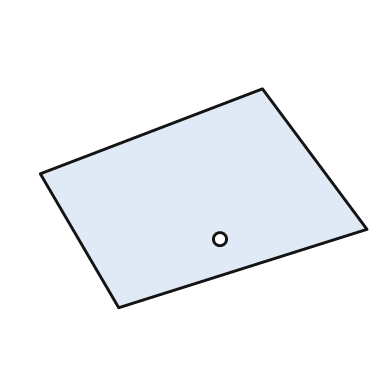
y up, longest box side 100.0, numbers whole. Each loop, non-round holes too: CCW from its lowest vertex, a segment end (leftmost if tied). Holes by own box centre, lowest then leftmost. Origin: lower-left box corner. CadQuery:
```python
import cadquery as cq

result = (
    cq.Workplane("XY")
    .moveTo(24.0, 0.0)
    .lineTo(100.0, 24.0)
    .lineTo(68.0, 67.0)
    .lineTo(0.0, 41.0)
    .close()
    .moveTo(55.0, 21.0)
    .circle(2.0)
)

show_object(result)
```